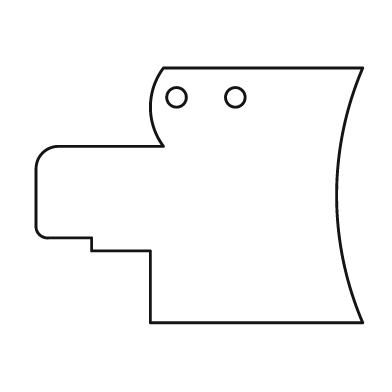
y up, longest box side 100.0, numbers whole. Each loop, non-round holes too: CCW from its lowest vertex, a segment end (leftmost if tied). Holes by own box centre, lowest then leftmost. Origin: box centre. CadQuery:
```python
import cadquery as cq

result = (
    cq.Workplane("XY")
    .moveTo(-15.0, -39.0)
    .lineTo(50.0, -39.0)
    .threePointArc((42.0, 0.0), (50.0, 39.0))
    .lineTo(-11.0, 39.0)
    .threePointArc((-15.0, 27.0), (-11.0, 15.0))
    .lineTo(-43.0, 15.0)
    .threePointArc((-48.0, 13.0), (-50.0, 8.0))
    .lineTo(-50.0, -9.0)
    .threePointArc((-49.0, -12.0), (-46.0, -13.0))
    .lineTo(-33.0, -13.0)
    .lineTo(-33.0, -17.0)
    .lineTo(-15.0, -17.0)
    .close()
    .moveTo(-7.0, 30.0)
    .circle(3.0)
    .moveTo(11.0, 30.0)
    .circle(3.0)
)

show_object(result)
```